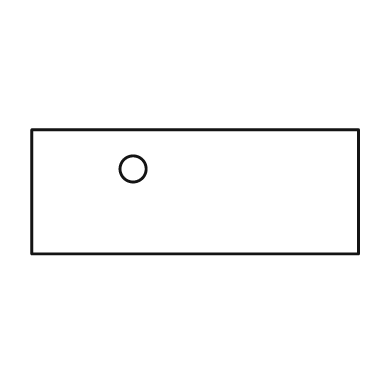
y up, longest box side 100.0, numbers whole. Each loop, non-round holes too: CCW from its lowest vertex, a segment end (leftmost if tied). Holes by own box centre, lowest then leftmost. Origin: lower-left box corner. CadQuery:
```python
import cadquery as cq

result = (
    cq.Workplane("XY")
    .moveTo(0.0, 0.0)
    .lineTo(100.0, 0.0)
    .lineTo(100.0, 38.0)
    .lineTo(0.0, 38.0)
    .close()
    .moveTo(31.0, 26.0)
    .circle(4.0)
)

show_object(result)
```